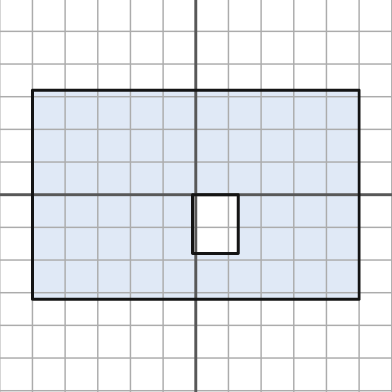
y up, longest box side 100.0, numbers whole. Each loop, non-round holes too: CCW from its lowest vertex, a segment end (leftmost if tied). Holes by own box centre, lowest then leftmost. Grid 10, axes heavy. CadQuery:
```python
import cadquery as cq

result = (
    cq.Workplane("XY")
    .moveTo(-50.0, -32.0)
    .lineTo(50.0, -32.0)
    .lineTo(50.0, 32.0)
    .lineTo(-50.0, 32.0)
    .close()
    .moveTo(-1.0, -18.0)
    .lineTo(13.0, -18.0)
    .lineTo(13.0, 0.0)
    .lineTo(-1.0, 0.0)
    .close()
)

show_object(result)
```